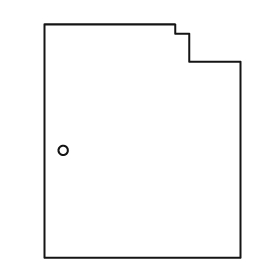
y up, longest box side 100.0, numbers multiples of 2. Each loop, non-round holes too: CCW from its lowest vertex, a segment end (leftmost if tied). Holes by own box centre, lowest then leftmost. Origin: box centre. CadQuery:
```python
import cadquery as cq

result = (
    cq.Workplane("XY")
    .moveTo(-42.0, -50.0)
    .lineTo(42.0, -50.0)
    .lineTo(42.0, 34.0)
    .lineTo(20.0, 34.0)
    .lineTo(20.0, 46.0)
    .lineTo(14.0, 46.0)
    .lineTo(14.0, 50.0)
    .lineTo(-42.0, 50.0)
    .close()
    .moveTo(-34.0, -4.0)
    .circle(2.0)
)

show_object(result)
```